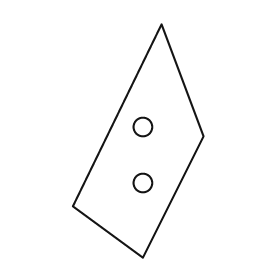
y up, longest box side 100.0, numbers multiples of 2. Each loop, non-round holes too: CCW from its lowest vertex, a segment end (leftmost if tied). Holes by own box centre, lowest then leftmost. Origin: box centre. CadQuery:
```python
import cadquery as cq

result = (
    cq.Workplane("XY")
    .moveTo(2.0, -50.0)
    .lineTo(28.0, 2.0)
    .lineTo(10.0, 50.0)
    .lineTo(-28.0, -28.0)
    .close()
    .moveTo(2.0, -18.0)
    .circle(4.0)
    .moveTo(2.0, 6.0)
    .circle(4.0)
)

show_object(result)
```